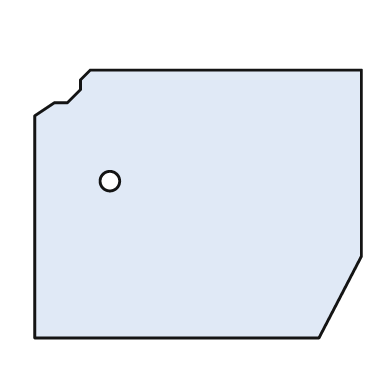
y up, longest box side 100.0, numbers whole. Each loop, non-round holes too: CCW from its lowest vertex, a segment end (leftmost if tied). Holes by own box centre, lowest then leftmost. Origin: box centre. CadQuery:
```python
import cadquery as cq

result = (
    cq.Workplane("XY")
    .moveTo(-50.0, -41.0)
    .lineTo(37.0, -41.0)
    .lineTo(50.0, -16.0)
    .lineTo(50.0, 41.0)
    .lineTo(-33.0, 41.0)
    .lineTo(-36.0, 38.0)
    .lineTo(-36.0, 35.0)
    .lineTo(-40.0, 31.0)
    .lineTo(-44.0, 31.0)
    .lineTo(-50.0, 27.0)
    .close()
    .moveTo(-27.0, 7.0)
    .circle(3.0)
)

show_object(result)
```